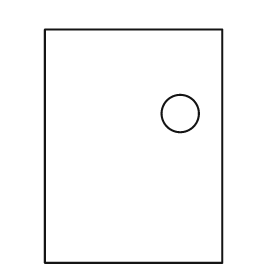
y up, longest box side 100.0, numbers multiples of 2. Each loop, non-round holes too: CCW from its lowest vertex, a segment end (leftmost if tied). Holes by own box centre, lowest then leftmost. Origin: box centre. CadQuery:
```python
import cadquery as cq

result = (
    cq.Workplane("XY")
    .moveTo(-38.0, -50.0)
    .lineTo(38.0, -50.0)
    .lineTo(38.0, 50.0)
    .lineTo(-38.0, 50.0)
    .close()
    .moveTo(20.0, 14.0)
    .circle(8.0)
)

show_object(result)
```